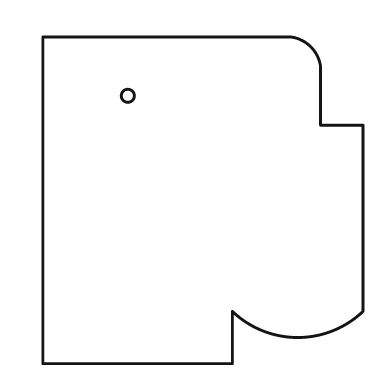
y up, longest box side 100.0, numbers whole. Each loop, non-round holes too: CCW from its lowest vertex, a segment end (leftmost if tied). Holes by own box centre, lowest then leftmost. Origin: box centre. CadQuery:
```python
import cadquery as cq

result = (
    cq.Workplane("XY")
    .moveTo(-49.0, -50.0)
    .lineTo(9.0, -50.0)
    .lineTo(9.0, -34.0)
    .threePointArc((29.0, -42.0), (49.0, -34.0))
    .lineTo(49.0, 23.0)
    .lineTo(36.0, 23.0)
    .lineTo(36.0, 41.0)
    .threePointArc((33.0, 47.0), (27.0, 50.0))
    .lineTo(-49.0, 50.0)
    .close()
    .moveTo(-23.0, 32.0)
    .circle(2.0)
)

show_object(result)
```